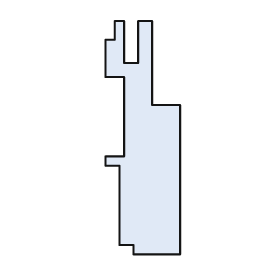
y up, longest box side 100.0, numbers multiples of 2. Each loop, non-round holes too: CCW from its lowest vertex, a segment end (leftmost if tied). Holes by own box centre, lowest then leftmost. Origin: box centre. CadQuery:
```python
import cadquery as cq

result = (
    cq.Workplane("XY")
    .moveTo(-4.0, -50.0)
    .lineTo(16.0, -50.0)
    .lineTo(16.0, 14.0)
    .lineTo(4.0, 14.0)
    .lineTo(4.0, 50.0)
    .lineTo(-2.0, 50.0)
    .lineTo(-2.0, 32.0)
    .lineTo(-8.0, 32.0)
    .lineTo(-8.0, 50.0)
    .lineTo(-12.0, 50.0)
    .lineTo(-12.0, 42.0)
    .lineTo(-16.0, 42.0)
    .lineTo(-16.0, 26.0)
    .lineTo(-8.0, 26.0)
    .lineTo(-8.0, -8.0)
    .lineTo(-16.0, -8.0)
    .lineTo(-16.0, -12.0)
    .lineTo(-10.0, -12.0)
    .lineTo(-10.0, -46.0)
    .lineTo(-4.0, -46.0)
    .close()
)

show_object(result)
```